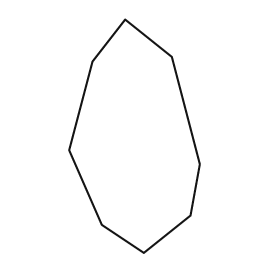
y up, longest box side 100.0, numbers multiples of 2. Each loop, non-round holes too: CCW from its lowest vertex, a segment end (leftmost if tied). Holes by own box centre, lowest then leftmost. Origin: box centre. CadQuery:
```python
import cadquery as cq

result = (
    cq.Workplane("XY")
    .moveTo(4.0, -50.0)
    .lineTo(24.0, -34.0)
    .lineTo(28.0, -12.0)
    .lineTo(16.0, 34.0)
    .lineTo(-4.0, 50.0)
    .lineTo(-18.0, 32.0)
    .lineTo(-28.0, -6.0)
    .lineTo(-14.0, -38.0)
    .close()
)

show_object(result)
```